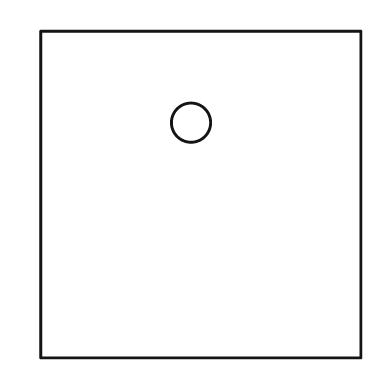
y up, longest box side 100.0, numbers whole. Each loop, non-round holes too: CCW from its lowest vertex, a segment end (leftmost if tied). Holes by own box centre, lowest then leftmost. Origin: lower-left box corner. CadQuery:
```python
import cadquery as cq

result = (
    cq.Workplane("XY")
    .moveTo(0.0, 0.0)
    .lineTo(98.0, 0.0)
    .lineTo(98.0, 100.0)
    .lineTo(0.0, 100.0)
    .close()
    .moveTo(46.0, 72.0)
    .circle(6.0)
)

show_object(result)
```